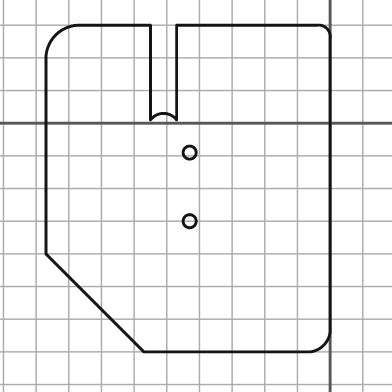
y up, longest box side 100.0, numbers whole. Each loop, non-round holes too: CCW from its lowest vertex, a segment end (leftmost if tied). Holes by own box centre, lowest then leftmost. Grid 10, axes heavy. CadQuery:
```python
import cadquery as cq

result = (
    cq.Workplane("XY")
    .moveTo(-57.0, -70.0)
    .lineTo(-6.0, -70.0)
    .threePointArc((-2.0, -68.0), (0.0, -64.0))
    .lineTo(0.0, 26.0)
    .threePointArc((-1.0, 29.0), (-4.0, 30.0))
    .lineTo(-47.0, 30.0)
    .lineTo(-47.0, 1.0)
    .threePointArc((-51.0, 3.0), (-55.0, 1.0))
    .lineTo(-55.0, 30.0)
    .lineTo(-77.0, 30.0)
    .threePointArc((-84.0, 27.0), (-87.0, 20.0))
    .lineTo(-87.0, -40.0)
    .close()
    .moveTo(-43.0, -30.0)
    .circle(2.0)
    .moveTo(-43.0, -9.0)
    .circle(2.0)
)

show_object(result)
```